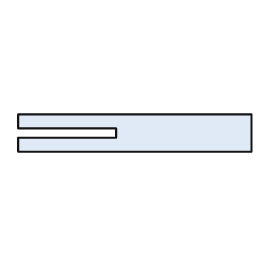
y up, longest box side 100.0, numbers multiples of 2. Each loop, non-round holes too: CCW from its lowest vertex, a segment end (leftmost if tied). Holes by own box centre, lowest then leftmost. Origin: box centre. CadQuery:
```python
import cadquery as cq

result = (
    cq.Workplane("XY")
    .moveTo(-50.0, -8.0)
    .lineTo(50.0, -8.0)
    .lineTo(50.0, 8.0)
    .lineTo(-50.0, 8.0)
    .lineTo(-50.0, 2.0)
    .lineTo(-8.0, 2.0)
    .lineTo(-8.0, -2.0)
    .lineTo(-50.0, -2.0)
    .close()
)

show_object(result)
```